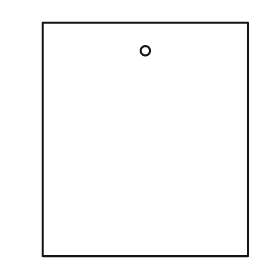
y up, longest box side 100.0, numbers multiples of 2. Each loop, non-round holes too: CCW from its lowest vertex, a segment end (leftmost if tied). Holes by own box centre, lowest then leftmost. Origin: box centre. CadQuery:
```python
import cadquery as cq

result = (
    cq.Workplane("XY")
    .moveTo(-44.0, -50.0)
    .lineTo(44.0, -50.0)
    .lineTo(44.0, 50.0)
    .lineTo(-44.0, 50.0)
    .close()
    .moveTo(0.0, 38.0)
    .circle(2.0)
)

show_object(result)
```